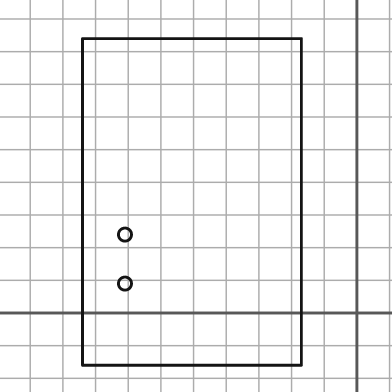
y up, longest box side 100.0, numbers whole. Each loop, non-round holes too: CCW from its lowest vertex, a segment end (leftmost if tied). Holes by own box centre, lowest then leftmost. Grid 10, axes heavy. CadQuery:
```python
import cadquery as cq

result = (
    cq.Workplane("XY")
    .moveTo(-84.0, -16.0)
    .lineTo(-17.0, -16.0)
    .lineTo(-17.0, 84.0)
    .lineTo(-84.0, 84.0)
    .close()
    .moveTo(-71.0, 9.0)
    .circle(2.0)
    .moveTo(-71.0, 24.0)
    .circle(2.0)
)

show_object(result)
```